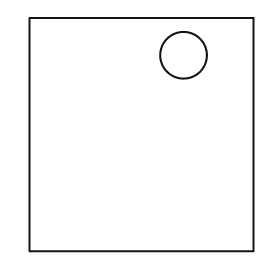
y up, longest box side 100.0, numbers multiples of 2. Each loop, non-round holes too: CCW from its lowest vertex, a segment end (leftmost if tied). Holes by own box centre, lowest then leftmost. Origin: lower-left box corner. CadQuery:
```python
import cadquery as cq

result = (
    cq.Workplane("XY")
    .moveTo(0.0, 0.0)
    .lineTo(96.0, 0.0)
    .lineTo(96.0, 100.0)
    .lineTo(0.0, 100.0)
    .close()
    .moveTo(66.0, 84.0)
    .circle(10.0)
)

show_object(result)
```